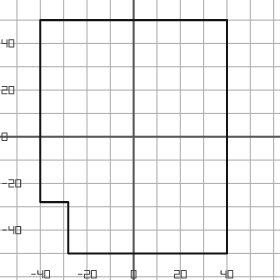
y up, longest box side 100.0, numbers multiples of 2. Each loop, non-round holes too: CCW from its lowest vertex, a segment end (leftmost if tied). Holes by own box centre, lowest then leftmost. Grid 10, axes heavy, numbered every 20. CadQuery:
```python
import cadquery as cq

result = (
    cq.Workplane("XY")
    .moveTo(-28.0, -50.0)
    .lineTo(40.0, -50.0)
    .lineTo(40.0, 50.0)
    .lineTo(-40.0, 50.0)
    .lineTo(-40.0, -28.0)
    .lineTo(-28.0, -28.0)
    .close()
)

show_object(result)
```